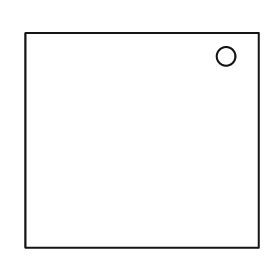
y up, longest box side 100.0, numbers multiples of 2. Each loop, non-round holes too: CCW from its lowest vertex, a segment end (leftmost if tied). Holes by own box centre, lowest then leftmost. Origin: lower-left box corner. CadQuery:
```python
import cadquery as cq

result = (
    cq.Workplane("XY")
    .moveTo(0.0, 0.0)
    .lineTo(100.0, 0.0)
    .lineTo(100.0, 92.0)
    .lineTo(0.0, 92.0)
    .close()
    .moveTo(86.0, 82.0)
    .circle(4.0)
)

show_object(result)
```